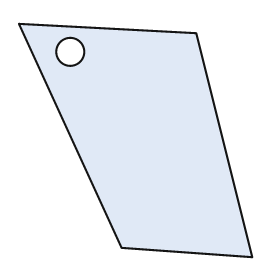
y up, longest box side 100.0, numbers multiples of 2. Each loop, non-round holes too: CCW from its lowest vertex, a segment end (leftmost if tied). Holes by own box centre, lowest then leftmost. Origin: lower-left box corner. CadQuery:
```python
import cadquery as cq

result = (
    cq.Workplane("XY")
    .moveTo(100.0, 0.0)
    .lineTo(76.0, 96.0)
    .lineTo(0.0, 100.0)
    .lineTo(44.0, 4.0)
    .close()
    .moveTo(22.0, 88.0)
    .circle(6.0)
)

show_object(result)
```